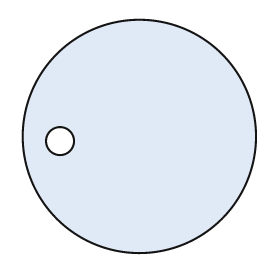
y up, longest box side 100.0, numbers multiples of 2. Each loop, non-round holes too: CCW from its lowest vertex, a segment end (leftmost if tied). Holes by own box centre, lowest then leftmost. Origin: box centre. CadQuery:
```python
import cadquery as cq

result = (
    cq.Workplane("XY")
    .moveTo(0.0, 0.0)
    .circle(50.0)
    .moveTo(-34.0, -2.0)
    .circle(6.0)
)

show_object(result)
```